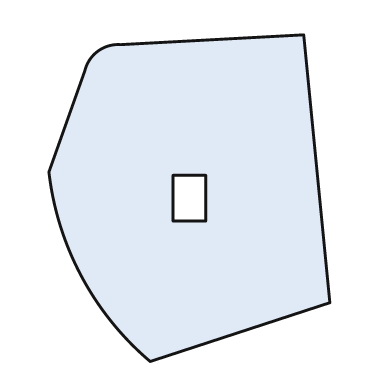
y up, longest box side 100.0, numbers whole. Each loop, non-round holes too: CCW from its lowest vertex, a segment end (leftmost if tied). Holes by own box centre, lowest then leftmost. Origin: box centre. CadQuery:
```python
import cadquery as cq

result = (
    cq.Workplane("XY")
    .moveTo(-12.0, -50.0)
    .lineTo(43.0, -32.0)
    .lineTo(35.0, 50.0)
    .lineTo(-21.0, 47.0)
    .threePointArc((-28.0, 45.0), (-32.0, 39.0))
    .lineTo(-43.0, 8.0)
    .threePointArc((-33.0, -24.0), (-12.0, -50.0))
    .close()
    .moveTo(-5.0, -7.0)
    .lineTo(5.0, -7.0)
    .lineTo(5.0, 7.0)
    .lineTo(-5.0, 7.0)
    .close()
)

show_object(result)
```